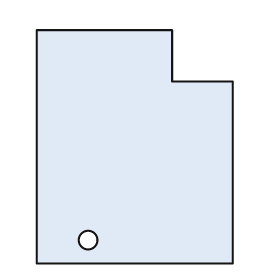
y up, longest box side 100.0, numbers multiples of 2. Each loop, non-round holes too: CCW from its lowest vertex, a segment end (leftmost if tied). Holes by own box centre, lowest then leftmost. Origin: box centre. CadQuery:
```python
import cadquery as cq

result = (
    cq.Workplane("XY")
    .moveTo(-42.0, -50.0)
    .lineTo(42.0, -50.0)
    .lineTo(42.0, 28.0)
    .lineTo(16.0, 28.0)
    .lineTo(16.0, 50.0)
    .lineTo(-42.0, 50.0)
    .close()
    .moveTo(-20.0, -40.0)
    .circle(4.0)
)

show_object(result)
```